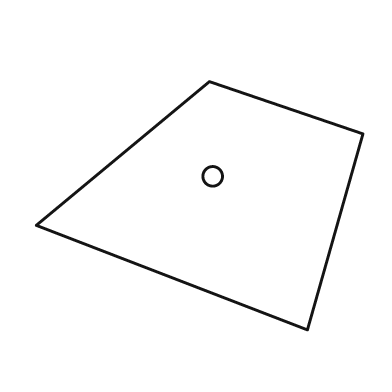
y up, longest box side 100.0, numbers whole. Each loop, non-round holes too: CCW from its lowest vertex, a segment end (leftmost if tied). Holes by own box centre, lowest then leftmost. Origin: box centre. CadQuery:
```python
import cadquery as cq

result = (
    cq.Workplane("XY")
    .moveTo(33.0, -38.0)
    .lineTo(50.0, 22.0)
    .lineTo(3.0, 38.0)
    .lineTo(-50.0, -6.0)
    .close()
    .moveTo(4.0, 9.0)
    .circle(3.0)
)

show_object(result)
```